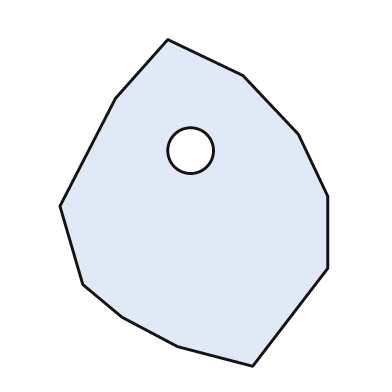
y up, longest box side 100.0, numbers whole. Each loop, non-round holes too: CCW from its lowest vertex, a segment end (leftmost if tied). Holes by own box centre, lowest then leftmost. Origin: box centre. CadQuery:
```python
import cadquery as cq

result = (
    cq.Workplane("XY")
    .moveTo(18.0, -50.0)
    .lineTo(41.0, -20.0)
    .lineTo(41.0, 2.0)
    .lineTo(32.0, 21.0)
    .lineTo(15.0, 39.0)
    .lineTo(-8.0, 50.0)
    .lineTo(-24.0, 32.0)
    .lineTo(-41.0, -1.0)
    .lineTo(-34.0, -25.0)
    .lineTo(-22.0, -35.0)
    .lineTo(-5.0, -44.0)
    .close()
    .moveTo(-1.0, 16.0)
    .circle(7.0)
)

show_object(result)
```